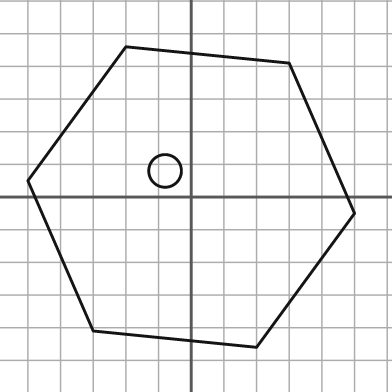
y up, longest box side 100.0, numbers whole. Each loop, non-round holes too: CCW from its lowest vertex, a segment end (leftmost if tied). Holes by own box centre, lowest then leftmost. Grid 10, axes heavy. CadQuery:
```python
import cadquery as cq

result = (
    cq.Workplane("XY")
    .moveTo(20.0, -46.0)
    .lineTo(50.0, -5.0)
    .lineTo(30.0, 41.0)
    .lineTo(-20.0, 46.0)
    .lineTo(-50.0, 5.0)
    .lineTo(-30.0, -41.0)
    .close()
    .moveTo(-8.0, 8.0)
    .circle(5.0)
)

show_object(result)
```